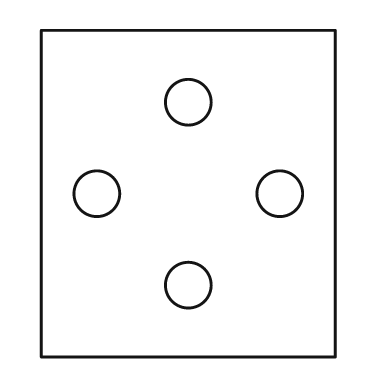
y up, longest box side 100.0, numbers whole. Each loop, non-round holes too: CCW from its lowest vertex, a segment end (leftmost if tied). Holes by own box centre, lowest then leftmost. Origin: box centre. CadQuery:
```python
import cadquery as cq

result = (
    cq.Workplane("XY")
    .moveTo(-45.0, -50.0)
    .lineTo(45.0, -50.0)
    .lineTo(45.0, 50.0)
    .lineTo(-45.0, 50.0)
    .close()
    .moveTo(0.0, -28.0)
    .circle(7.0)
    .moveTo(-28.0, 0.0)
    .circle(7.0)
    .moveTo(28.0, 0.0)
    .circle(7.0)
    .moveTo(0.0, 28.0)
    .circle(7.0)
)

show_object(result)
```